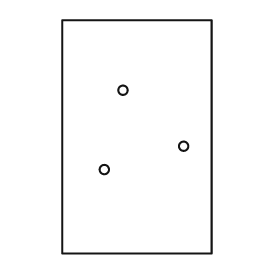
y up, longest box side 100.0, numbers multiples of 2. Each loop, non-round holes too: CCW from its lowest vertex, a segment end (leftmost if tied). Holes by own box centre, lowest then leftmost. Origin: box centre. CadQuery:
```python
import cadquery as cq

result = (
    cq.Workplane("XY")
    .moveTo(-32.0, -50.0)
    .lineTo(32.0, -50.0)
    .lineTo(32.0, 50.0)
    .lineTo(-32.0, 50.0)
    .close()
    .moveTo(-14.0, -14.0)
    .circle(2.0)
    .moveTo(20.0, -4.0)
    .circle(2.0)
    .moveTo(-6.0, 20.0)
    .circle(2.0)
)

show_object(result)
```